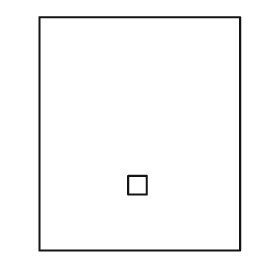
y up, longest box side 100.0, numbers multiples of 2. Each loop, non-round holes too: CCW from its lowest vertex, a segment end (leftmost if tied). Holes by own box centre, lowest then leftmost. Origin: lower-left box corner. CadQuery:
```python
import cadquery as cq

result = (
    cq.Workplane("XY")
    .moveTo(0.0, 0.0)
    .lineTo(86.0, 0.0)
    .lineTo(86.0, 100.0)
    .lineTo(0.0, 100.0)
    .close()
    .moveTo(38.0, 24.0)
    .lineTo(46.0, 24.0)
    .lineTo(46.0, 32.0)
    .lineTo(38.0, 32.0)
    .close()
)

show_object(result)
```